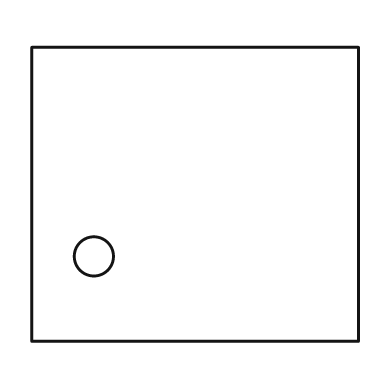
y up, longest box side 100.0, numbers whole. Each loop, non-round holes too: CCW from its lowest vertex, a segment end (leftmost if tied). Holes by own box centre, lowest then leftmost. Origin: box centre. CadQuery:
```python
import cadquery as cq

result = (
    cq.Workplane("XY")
    .moveTo(-50.0, -45.0)
    .lineTo(50.0, -45.0)
    .lineTo(50.0, 45.0)
    .lineTo(-50.0, 45.0)
    .close()
    .moveTo(-31.0, -19.0)
    .circle(6.0)
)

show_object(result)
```